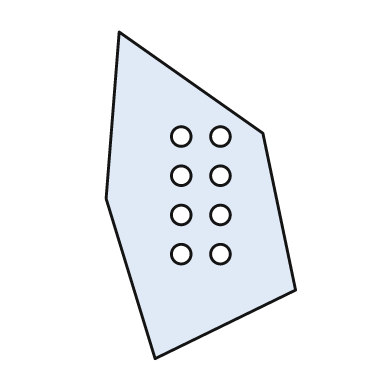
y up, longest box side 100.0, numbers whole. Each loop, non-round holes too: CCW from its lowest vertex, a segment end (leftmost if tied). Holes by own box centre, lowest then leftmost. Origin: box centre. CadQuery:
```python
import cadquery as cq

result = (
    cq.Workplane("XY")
    .moveTo(-14.0, -50.0)
    .lineTo(29.0, -29.0)
    .lineTo(19.0, 19.0)
    .lineTo(-25.0, 50.0)
    .lineTo(-29.0, -1.0)
    .close()
    .moveTo(-6.0, -18.0)
    .circle(3.0)
    .moveTo(6.0, -18.0)
    .circle(3.0)
    .moveTo(-6.0, -6.0)
    .circle(3.0)
    .moveTo(6.0, -6.0)
    .circle(3.0)
    .moveTo(-6.0, 6.0)
    .circle(3.0)
    .moveTo(6.0, 6.0)
    .circle(3.0)
    .moveTo(-6.0, 18.0)
    .circle(3.0)
    .moveTo(6.0, 18.0)
    .circle(3.0)
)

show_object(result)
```